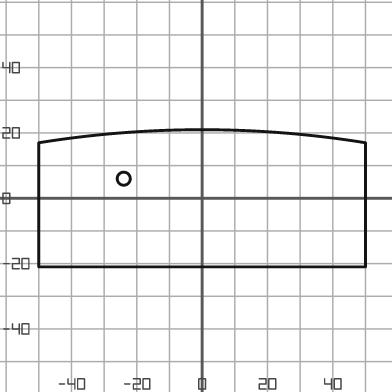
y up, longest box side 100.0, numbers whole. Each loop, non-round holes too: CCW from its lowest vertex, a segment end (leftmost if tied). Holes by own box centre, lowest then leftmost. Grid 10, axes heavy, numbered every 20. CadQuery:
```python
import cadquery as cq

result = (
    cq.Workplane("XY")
    .moveTo(-50.0, -21.0)
    .lineTo(50.0, -21.0)
    .lineTo(50.0, 17.0)
    .threePointArc((0.0, 21.0), (-50.0, 17.0))
    .close()
    .moveTo(-24.0, 6.0)
    .circle(2.0)
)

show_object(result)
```